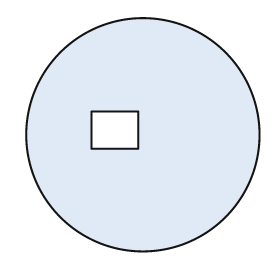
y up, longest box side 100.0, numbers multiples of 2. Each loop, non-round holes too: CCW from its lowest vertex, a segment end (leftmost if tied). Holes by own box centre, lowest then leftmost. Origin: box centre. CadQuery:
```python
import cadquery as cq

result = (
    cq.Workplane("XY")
    .moveTo(0.0, 0.0)
    .circle(50.0)
    .moveTo(-22.0, -6.0)
    .lineTo(-2.0, -6.0)
    .lineTo(-2.0, 10.0)
    .lineTo(-22.0, 10.0)
    .close()
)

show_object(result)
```